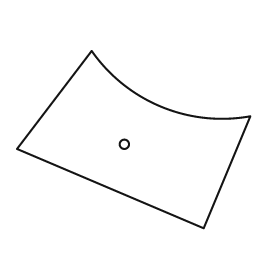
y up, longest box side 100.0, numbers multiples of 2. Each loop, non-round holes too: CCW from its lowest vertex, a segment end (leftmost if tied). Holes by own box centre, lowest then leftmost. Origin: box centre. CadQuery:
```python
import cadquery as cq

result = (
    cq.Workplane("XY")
    .moveTo(30.0, -38.0)
    .lineTo(50.0, 10.0)
    .threePointArc((12.0, 14.0), (-18.0, 38.0))
    .lineTo(-50.0, -4.0)
    .close()
    .moveTo(-4.0, -2.0)
    .circle(2.0)
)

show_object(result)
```